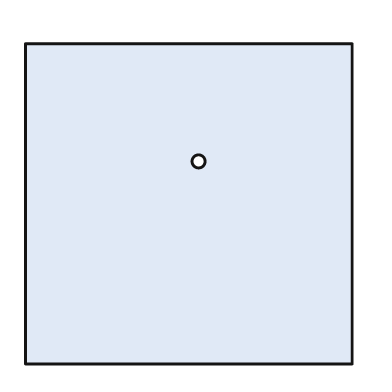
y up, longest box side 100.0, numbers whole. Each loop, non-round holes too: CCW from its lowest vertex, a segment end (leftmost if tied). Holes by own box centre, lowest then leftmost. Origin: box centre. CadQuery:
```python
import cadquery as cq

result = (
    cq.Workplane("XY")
    .moveTo(-50.0, -49.0)
    .lineTo(50.0, -49.0)
    .lineTo(50.0, 49.0)
    .lineTo(-50.0, 49.0)
    .close()
    .moveTo(3.0, 13.0)
    .circle(2.0)
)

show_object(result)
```